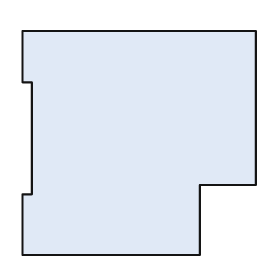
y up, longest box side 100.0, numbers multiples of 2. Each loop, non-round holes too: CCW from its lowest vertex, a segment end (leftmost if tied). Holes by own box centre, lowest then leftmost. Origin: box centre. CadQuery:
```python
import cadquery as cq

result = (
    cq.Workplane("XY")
    .moveTo(-50.0, -48.0)
    .lineTo(26.0, -48.0)
    .lineTo(26.0, -18.0)
    .lineTo(50.0, -18.0)
    .lineTo(50.0, 48.0)
    .lineTo(-50.0, 48.0)
    .lineTo(-50.0, 26.0)
    .lineTo(-46.0, 26.0)
    .lineTo(-46.0, -22.0)
    .lineTo(-50.0, -22.0)
    .close()
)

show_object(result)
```